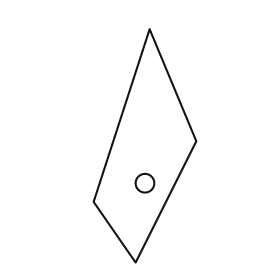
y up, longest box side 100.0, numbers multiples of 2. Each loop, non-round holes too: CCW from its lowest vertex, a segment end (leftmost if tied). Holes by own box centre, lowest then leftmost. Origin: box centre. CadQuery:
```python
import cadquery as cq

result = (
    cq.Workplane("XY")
    .moveTo(-4.0, -50.0)
    .lineTo(22.0, 2.0)
    .lineTo(2.0, 50.0)
    .lineTo(-22.0, -24.0)
    .close()
    .moveTo(0.0, -16.0)
    .circle(4.0)
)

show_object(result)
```